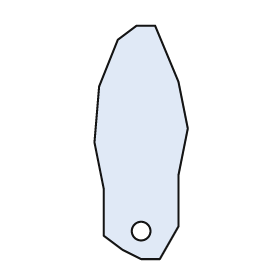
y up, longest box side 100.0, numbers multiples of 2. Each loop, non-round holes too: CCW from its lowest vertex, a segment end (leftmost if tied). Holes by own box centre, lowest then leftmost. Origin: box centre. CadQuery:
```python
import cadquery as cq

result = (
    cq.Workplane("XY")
    .moveTo(0.0, -50.0)
    .lineTo(8.0, -50.0)
    .lineTo(16.0, -36.0)
    .lineTo(16.0, -14.0)
    .lineTo(20.0, 6.0)
    .lineTo(16.0, 26.0)
    .lineTo(6.0, 50.0)
    .lineTo(-2.0, 50.0)
    .lineTo(-10.0, 44.0)
    .lineTo(-18.0, 24.0)
    .lineTo(-20.0, 0.0)
    .lineTo(-16.0, -20.0)
    .lineTo(-16.0, -40.0)
    .lineTo(-8.0, -46.0)
    .close()
    .moveTo(0.0, -38.0)
    .circle(4.0)
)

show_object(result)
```